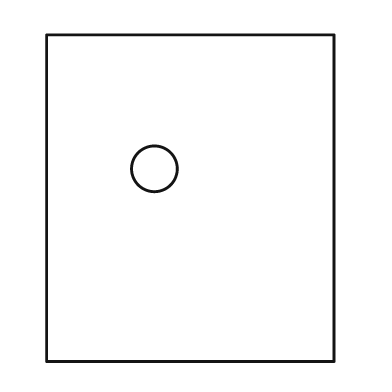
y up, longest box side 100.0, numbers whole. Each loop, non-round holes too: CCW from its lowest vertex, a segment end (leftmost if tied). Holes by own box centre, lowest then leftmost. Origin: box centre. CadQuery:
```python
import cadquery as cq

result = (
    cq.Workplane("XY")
    .moveTo(-44.0, -50.0)
    .lineTo(44.0, -50.0)
    .lineTo(44.0, 50.0)
    .lineTo(-44.0, 50.0)
    .close()
    .moveTo(-11.0, 9.0)
    .circle(7.0)
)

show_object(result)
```